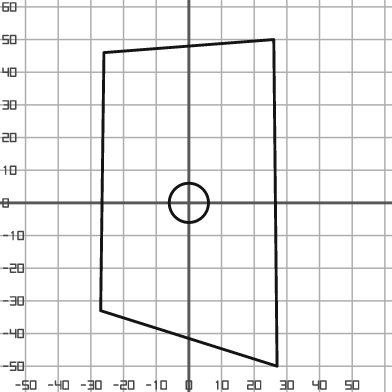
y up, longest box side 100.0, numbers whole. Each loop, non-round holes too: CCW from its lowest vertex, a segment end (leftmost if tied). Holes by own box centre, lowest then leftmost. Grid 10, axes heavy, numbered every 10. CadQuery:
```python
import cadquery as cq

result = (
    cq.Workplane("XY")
    .moveTo(27.0, -50.0)
    .lineTo(26.0, 50.0)
    .lineTo(-26.0, 46.0)
    .lineTo(-27.0, -33.0)
    .close()
    .moveTo(0.0, 0.0)
    .circle(6.0)
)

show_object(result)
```